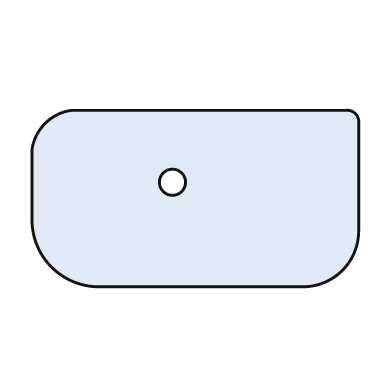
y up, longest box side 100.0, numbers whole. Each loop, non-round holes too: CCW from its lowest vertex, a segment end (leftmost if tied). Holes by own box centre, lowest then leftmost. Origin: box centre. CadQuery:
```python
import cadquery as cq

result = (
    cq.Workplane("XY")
    .moveTo(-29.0, -27.0)
    .lineTo(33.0, -27.0)
    .threePointArc((45.0, -22.0), (50.0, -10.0))
    .lineTo(50.0, 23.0)
    .threePointArc((49.0, 26.0), (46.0, 27.0))
    .lineTo(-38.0, 27.0)
    .threePointArc((-46.0, 23.0), (-50.0, 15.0))
    .lineTo(-50.0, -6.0)
    .threePointArc((-44.0, -21.0), (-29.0, -27.0))
    .close()
    .moveTo(-7.0, 5.0)
    .circle(4.0)
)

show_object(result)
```